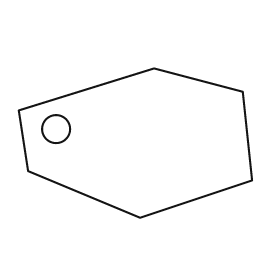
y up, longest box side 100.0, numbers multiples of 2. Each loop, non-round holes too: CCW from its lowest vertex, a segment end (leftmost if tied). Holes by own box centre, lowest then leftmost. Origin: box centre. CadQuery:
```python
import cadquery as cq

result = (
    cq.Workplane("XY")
    .moveTo(2.0, -32.0)
    .lineTo(50.0, -16.0)
    .lineTo(46.0, 22.0)
    .lineTo(8.0, 32.0)
    .lineTo(-50.0, 14.0)
    .lineTo(-46.0, -12.0)
    .close()
    .moveTo(-34.0, 6.0)
    .circle(6.0)
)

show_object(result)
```